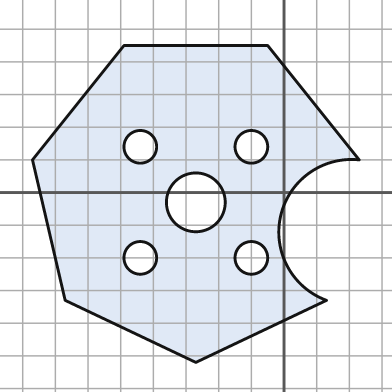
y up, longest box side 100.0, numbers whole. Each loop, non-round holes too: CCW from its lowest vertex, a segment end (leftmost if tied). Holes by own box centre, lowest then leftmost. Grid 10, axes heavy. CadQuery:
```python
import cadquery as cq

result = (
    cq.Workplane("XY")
    .moveTo(-27.0, -52.0)
    .lineTo(13.0, -33.0)
    .threePointArc((-1.0, -7.0), (23.0, 10.0))
    .lineTo(-5.0, 45.0)
    .lineTo(-49.0, 45.0)
    .lineTo(-77.0, 10.0)
    .lineTo(-67.0, -33.0)
    .close()
    .moveTo(-44.0, -20.0)
    .circle(5.0)
    .moveTo(-10.0, -20.0)
    .circle(5.0)
    .moveTo(-27.0, -3.0)
    .circle(9.0)
    .moveTo(-44.0, 14.0)
    .circle(5.0)
    .moveTo(-10.0, 14.0)
    .circle(5.0)
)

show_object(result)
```